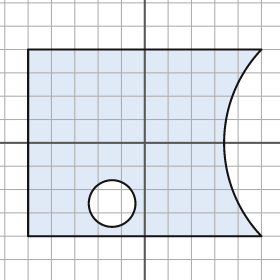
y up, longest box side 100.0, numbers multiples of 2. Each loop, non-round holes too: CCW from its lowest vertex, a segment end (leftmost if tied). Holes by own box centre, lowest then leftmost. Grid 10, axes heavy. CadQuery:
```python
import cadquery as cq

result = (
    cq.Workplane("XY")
    .moveTo(-50.0, -40.0)
    .lineTo(50.0, -40.0)
    .threePointArc((34.0, 0.0), (50.0, 40.0))
    .lineTo(-50.0, 40.0)
    .close()
    .moveTo(-14.0, -26.0)
    .circle(10.0)
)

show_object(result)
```